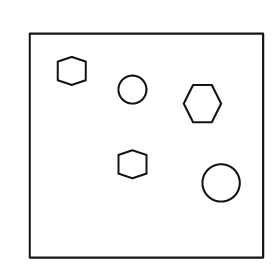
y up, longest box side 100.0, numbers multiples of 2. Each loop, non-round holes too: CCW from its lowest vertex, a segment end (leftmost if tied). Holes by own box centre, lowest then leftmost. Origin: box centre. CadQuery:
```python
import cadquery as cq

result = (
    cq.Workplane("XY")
    .moveTo(-50.0, -48.0)
    .lineTo(50.0, -48.0)
    .lineTo(50.0, 48.0)
    .lineTo(-50.0, 48.0)
    .close()
    .moveTo(32.0, -16.0)
    .circle(8.0)
    .moveTo(-6.0, -14.0)
    .lineTo(0.0, -12.0)
    .lineTo(0.0, -4.0)
    .lineTo(-6.0, -2.0)
    .lineTo(-12.0, -4.0)
    .lineTo(-12.0, -12.0)
    .close()
    .moveTo(20.0, 10.0)
    .lineTo(28.0, 10.0)
    .lineTo(32.0, 18.0)
    .lineTo(28.0, 26.0)
    .lineTo(20.0, 26.0)
    .lineTo(16.0, 18.0)
    .close()
    .moveTo(-6.0, 24.0)
    .circle(6.0)
    .moveTo(-32.0, 26.0)
    .lineTo(-26.0, 28.0)
    .lineTo(-26.0, 36.0)
    .lineTo(-32.0, 38.0)
    .lineTo(-38.0, 36.0)
    .lineTo(-38.0, 28.0)
    .close()
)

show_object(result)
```